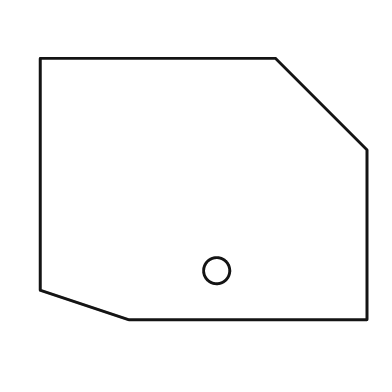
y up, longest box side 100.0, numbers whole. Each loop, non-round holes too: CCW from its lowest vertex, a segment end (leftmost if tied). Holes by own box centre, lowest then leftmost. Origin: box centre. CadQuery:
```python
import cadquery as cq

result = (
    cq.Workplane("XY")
    .moveTo(-23.0, -40.0)
    .lineTo(50.0, -40.0)
    .lineTo(50.0, 12.0)
    .lineTo(22.0, 40.0)
    .lineTo(-50.0, 40.0)
    .lineTo(-50.0, -31.0)
    .close()
    .moveTo(4.0, -25.0)
    .circle(4.0)
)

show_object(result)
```